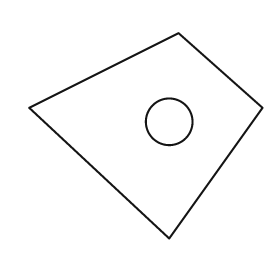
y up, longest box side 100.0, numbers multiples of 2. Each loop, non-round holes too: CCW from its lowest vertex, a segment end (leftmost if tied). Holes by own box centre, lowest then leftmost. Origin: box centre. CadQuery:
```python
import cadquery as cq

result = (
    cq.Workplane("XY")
    .moveTo(10.0, -44.0)
    .lineTo(50.0, 12.0)
    .lineTo(14.0, 44.0)
    .lineTo(-50.0, 12.0)
    .close()
    .moveTo(10.0, 6.0)
    .circle(10.0)
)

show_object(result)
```